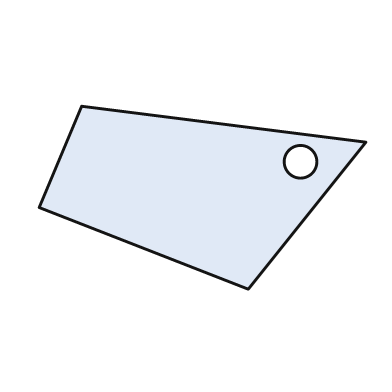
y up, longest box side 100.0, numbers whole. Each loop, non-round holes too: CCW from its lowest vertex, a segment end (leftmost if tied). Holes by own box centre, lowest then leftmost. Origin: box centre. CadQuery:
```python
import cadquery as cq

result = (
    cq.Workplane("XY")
    .moveTo(14.0, -28.0)
    .lineTo(50.0, 17.0)
    .lineTo(-37.0, 28.0)
    .lineTo(-50.0, -3.0)
    .close()
    .moveTo(30.0, 11.0)
    .circle(5.0)
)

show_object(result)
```